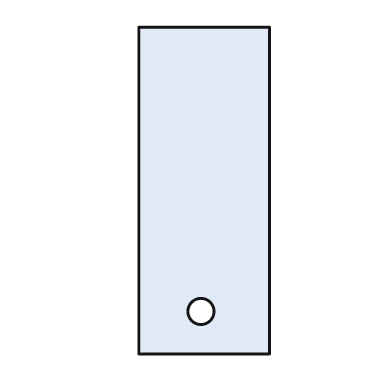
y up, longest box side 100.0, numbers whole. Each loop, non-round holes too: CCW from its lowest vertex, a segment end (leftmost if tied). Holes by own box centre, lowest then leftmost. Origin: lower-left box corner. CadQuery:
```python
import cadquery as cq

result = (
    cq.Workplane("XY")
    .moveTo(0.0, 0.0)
    .lineTo(40.0, 0.0)
    .lineTo(40.0, 100.0)
    .lineTo(0.0, 100.0)
    .close()
    .moveTo(19.0, 13.0)
    .circle(4.0)
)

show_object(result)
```